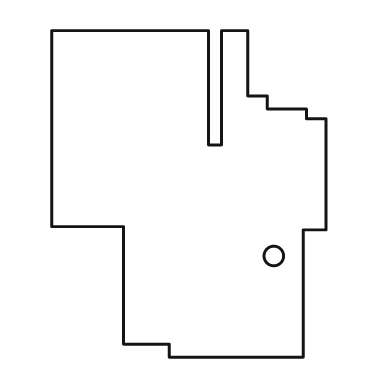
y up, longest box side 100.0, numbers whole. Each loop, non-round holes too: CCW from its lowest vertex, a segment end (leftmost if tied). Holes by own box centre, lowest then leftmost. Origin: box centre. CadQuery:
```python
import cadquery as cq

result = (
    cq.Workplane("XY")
    .moveTo(-6.0, -50.0)
    .lineTo(35.0, -50.0)
    .lineTo(35.0, -11.0)
    .lineTo(42.0, -11.0)
    .lineTo(42.0, 23.0)
    .lineTo(36.0, 23.0)
    .lineTo(36.0, 26.0)
    .lineTo(24.0, 26.0)
    .lineTo(24.0, 30.0)
    .lineTo(18.0, 30.0)
    .lineTo(18.0, 50.0)
    .lineTo(10.0, 50.0)
    .lineTo(10.0, 15.0)
    .lineTo(6.0, 15.0)
    .lineTo(6.0, 50.0)
    .lineTo(-42.0, 50.0)
    .lineTo(-42.0, -10.0)
    .lineTo(-20.0, -10.0)
    .lineTo(-20.0, -46.0)
    .lineTo(-6.0, -46.0)
    .close()
    .moveTo(26.0, -19.0)
    .circle(3.0)
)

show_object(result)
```